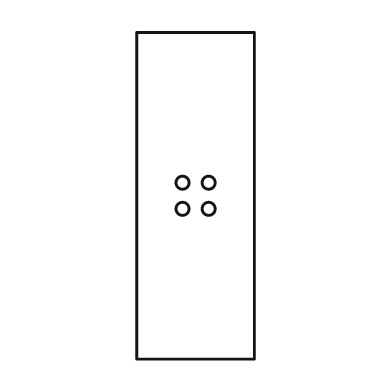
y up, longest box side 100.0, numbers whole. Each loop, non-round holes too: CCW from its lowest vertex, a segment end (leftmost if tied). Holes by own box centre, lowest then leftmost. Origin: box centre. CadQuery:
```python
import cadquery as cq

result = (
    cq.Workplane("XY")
    .moveTo(-18.0, -50.0)
    .lineTo(18.0, -50.0)
    .lineTo(18.0, 50.0)
    .lineTo(-18.0, 50.0)
    .close()
    .moveTo(-4.0, -4.0)
    .circle(2.0)
    .moveTo(4.0, -4.0)
    .circle(2.0)
    .moveTo(-4.0, 4.0)
    .circle(2.0)
    .moveTo(4.0, 4.0)
    .circle(2.0)
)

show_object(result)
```